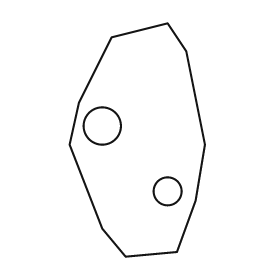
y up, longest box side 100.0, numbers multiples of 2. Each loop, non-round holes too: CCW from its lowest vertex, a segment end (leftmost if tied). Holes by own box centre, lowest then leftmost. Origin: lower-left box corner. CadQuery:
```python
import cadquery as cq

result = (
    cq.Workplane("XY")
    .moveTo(24.0, 0.0)
    .lineTo(46.0, 2.0)
    .lineTo(54.0, 24.0)
    .lineTo(58.0, 48.0)
    .lineTo(50.0, 88.0)
    .lineTo(42.0, 100.0)
    .lineTo(18.0, 94.0)
    .lineTo(4.0, 66.0)
    .lineTo(0.0, 48.0)
    .lineTo(14.0, 12.0)
    .close()
    .moveTo(42.0, 28.0)
    .circle(6.0)
    .moveTo(14.0, 56.0)
    .circle(8.0)
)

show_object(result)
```